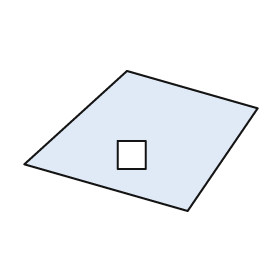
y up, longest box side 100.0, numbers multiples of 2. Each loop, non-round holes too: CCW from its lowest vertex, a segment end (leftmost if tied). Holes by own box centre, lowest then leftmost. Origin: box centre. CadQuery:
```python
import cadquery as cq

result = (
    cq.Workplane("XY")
    .moveTo(20.0, -30.0)
    .lineTo(50.0, 14.0)
    .lineTo(-6.0, 30.0)
    .lineTo(-50.0, -10.0)
    .close()
    .moveTo(-10.0, -12.0)
    .lineTo(2.0, -12.0)
    .lineTo(2.0, 0.0)
    .lineTo(-10.0, 0.0)
    .close()
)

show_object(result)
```